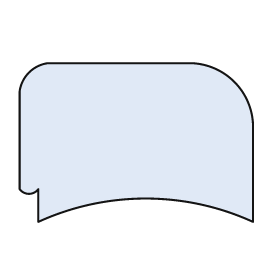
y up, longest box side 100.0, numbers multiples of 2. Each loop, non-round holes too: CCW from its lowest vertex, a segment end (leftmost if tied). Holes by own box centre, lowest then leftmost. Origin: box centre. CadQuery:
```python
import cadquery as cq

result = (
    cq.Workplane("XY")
    .moveTo(-42.0, -34.0)
    .threePointArc((4.0, -24.0), (50.0, -34.0))
    .lineTo(50.0, 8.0)
    .threePointArc((42.0, 26.0), (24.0, 34.0))
    .lineTo(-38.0, 34.0)
    .threePointArc((-46.0, 30.0), (-50.0, 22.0))
    .lineTo(-50.0, -20.0)
    .threePointArc((-46.0, -22.0), (-42.0, -20.0))
    .close()
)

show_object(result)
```